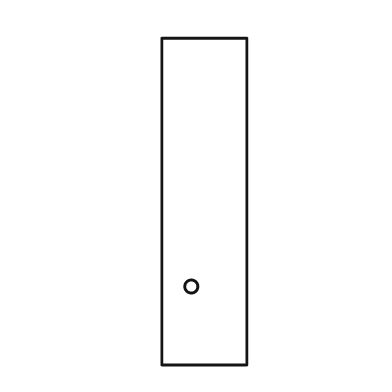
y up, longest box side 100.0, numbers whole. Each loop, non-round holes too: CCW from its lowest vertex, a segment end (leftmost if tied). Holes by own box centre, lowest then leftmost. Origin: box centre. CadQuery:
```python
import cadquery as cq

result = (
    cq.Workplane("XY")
    .moveTo(-13.0, -50.0)
    .lineTo(13.0, -50.0)
    .lineTo(13.0, 50.0)
    .lineTo(-13.0, 50.0)
    .close()
    .moveTo(-4.0, -26.0)
    .circle(2.0)
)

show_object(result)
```